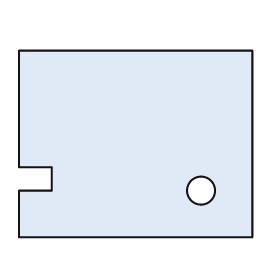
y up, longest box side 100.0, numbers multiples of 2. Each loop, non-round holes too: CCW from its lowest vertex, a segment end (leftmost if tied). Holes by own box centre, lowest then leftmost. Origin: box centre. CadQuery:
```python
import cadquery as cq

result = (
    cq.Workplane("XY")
    .moveTo(-50.0, -40.0)
    .lineTo(50.0, -40.0)
    .lineTo(50.0, 40.0)
    .lineTo(-50.0, 40.0)
    .lineTo(-50.0, -10.0)
    .lineTo(-36.0, -10.0)
    .lineTo(-36.0, -20.0)
    .lineTo(-50.0, -20.0)
    .close()
    .moveTo(28.0, -20.0)
    .circle(6.0)
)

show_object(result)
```